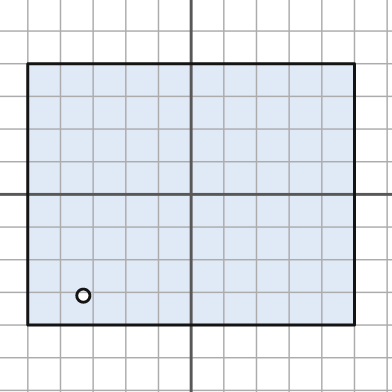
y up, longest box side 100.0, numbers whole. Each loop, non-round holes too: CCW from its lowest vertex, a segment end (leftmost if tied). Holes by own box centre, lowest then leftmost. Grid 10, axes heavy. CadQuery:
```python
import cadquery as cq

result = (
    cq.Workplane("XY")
    .moveTo(-50.0, -40.0)
    .lineTo(50.0, -40.0)
    .lineTo(50.0, 40.0)
    .lineTo(-50.0, 40.0)
    .close()
    .moveTo(-33.0, -31.0)
    .circle(2.0)
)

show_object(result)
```